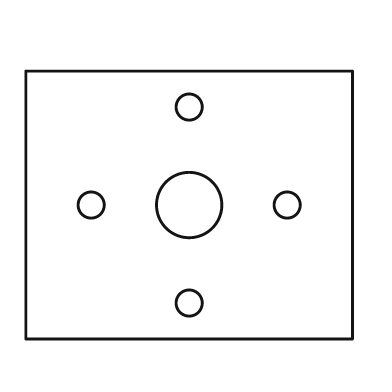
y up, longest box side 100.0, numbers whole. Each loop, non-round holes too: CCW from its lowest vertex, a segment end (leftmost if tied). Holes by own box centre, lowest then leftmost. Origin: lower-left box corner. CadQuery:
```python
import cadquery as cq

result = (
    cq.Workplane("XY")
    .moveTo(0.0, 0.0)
    .lineTo(100.0, 0.0)
    .lineTo(100.0, 82.0)
    .lineTo(0.0, 82.0)
    .close()
    .moveTo(50.0, 11.0)
    .circle(4.0)
    .moveTo(20.0, 41.0)
    .circle(4.0)
    .moveTo(50.0, 41.0)
    .circle(10.0)
    .moveTo(80.0, 41.0)
    .circle(4.0)
    .moveTo(50.0, 71.0)
    .circle(4.0)
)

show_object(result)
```